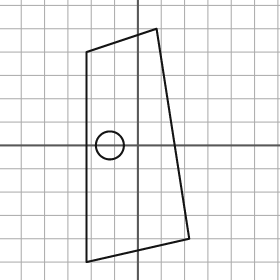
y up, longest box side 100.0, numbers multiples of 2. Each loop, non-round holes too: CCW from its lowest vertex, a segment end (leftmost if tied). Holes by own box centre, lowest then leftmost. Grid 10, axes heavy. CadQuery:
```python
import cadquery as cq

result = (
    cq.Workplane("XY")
    .moveTo(-22.0, -50.0)
    .lineTo(22.0, -40.0)
    .lineTo(8.0, 50.0)
    .lineTo(-22.0, 40.0)
    .close()
    .moveTo(-12.0, 0.0)
    .circle(6.0)
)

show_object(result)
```